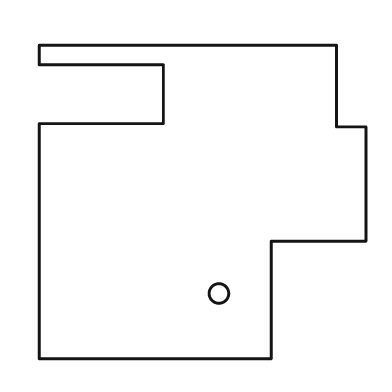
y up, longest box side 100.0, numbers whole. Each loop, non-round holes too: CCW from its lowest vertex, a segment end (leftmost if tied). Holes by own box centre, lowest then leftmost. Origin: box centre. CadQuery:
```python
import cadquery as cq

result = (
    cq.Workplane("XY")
    .moveTo(-50.0, -48.0)
    .lineTo(21.0, -48.0)
    .lineTo(21.0, -12.0)
    .lineTo(50.0, -12.0)
    .lineTo(50.0, 23.0)
    .lineTo(41.0, 23.0)
    .lineTo(41.0, 48.0)
    .lineTo(-50.0, 48.0)
    .lineTo(-50.0, 42.0)
    .lineTo(-12.0, 42.0)
    .lineTo(-12.0, 24.0)
    .lineTo(-50.0, 24.0)
    .close()
    .moveTo(5.0, -28.0)
    .circle(3.0)
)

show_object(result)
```